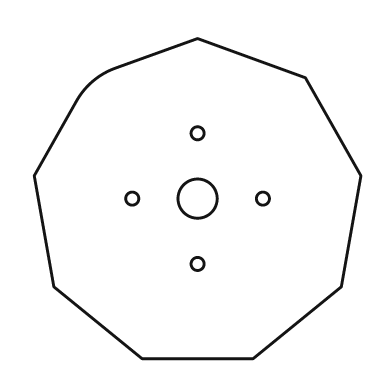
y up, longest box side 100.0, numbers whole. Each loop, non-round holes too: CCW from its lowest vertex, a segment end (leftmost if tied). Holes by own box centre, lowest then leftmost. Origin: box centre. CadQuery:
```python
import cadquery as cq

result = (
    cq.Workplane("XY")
    .moveTo(-17.0, -49.0)
    .lineTo(17.0, -49.0)
    .lineTo(44.0, -27.0)
    .lineTo(50.0, 7.0)
    .lineTo(33.0, 37.0)
    .lineTo(0.0, 49.0)
    .lineTo(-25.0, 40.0)
    .threePointArc((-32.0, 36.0), (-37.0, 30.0))
    .lineTo(-50.0, 7.0)
    .lineTo(-44.0, -27.0)
    .close()
    .moveTo(0.0, -20.0)
    .circle(2.0)
    .moveTo(-20.0, 0.0)
    .circle(2.0)
    .moveTo(0.0, 0.0)
    .circle(6.0)
    .moveTo(20.0, 0.0)
    .circle(2.0)
    .moveTo(0.0, 20.0)
    .circle(2.0)
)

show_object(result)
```